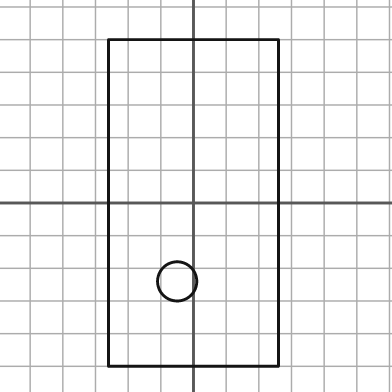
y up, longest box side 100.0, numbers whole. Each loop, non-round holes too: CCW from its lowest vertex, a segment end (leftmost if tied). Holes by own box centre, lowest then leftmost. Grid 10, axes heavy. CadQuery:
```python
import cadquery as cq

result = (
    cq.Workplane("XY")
    .moveTo(-26.0, -50.0)
    .lineTo(26.0, -50.0)
    .lineTo(26.0, 50.0)
    .lineTo(-26.0, 50.0)
    .close()
    .moveTo(-5.0, -24.0)
    .circle(6.0)
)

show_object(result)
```